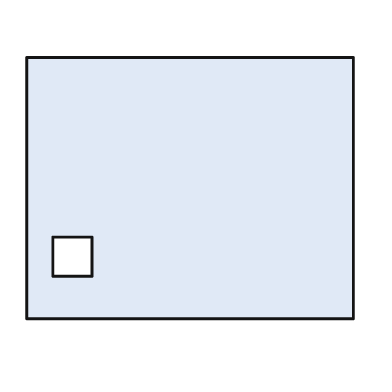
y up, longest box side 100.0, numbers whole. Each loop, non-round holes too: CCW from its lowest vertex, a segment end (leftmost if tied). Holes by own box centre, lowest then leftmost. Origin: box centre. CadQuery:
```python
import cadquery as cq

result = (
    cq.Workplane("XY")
    .moveTo(-50.0, -40.0)
    .lineTo(50.0, -40.0)
    .lineTo(50.0, 40.0)
    .lineTo(-50.0, 40.0)
    .close()
    .moveTo(-42.0, -27.0)
    .lineTo(-30.0, -27.0)
    .lineTo(-30.0, -15.0)
    .lineTo(-42.0, -15.0)
    .close()
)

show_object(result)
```